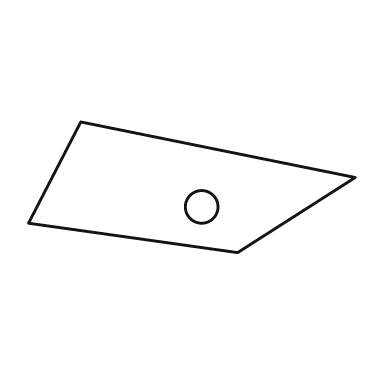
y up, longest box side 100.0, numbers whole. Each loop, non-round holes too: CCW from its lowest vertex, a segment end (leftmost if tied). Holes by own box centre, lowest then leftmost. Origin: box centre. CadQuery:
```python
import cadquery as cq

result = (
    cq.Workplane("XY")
    .moveTo(14.0, -20.0)
    .lineTo(50.0, 3.0)
    .lineTo(-34.0, 20.0)
    .lineTo(-50.0, -11.0)
    .close()
    .moveTo(3.0, -6.0)
    .circle(5.0)
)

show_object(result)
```